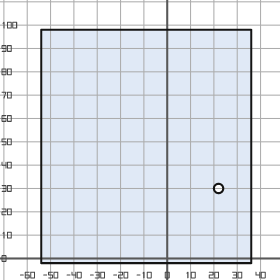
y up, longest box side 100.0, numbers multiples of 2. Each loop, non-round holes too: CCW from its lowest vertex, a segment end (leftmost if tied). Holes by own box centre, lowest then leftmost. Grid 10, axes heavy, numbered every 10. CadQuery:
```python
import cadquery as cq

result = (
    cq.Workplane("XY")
    .moveTo(-54.0, -2.0)
    .lineTo(36.0, -2.0)
    .lineTo(36.0, 98.0)
    .lineTo(-54.0, 98.0)
    .close()
    .moveTo(22.0, 30.0)
    .circle(2.0)
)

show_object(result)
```